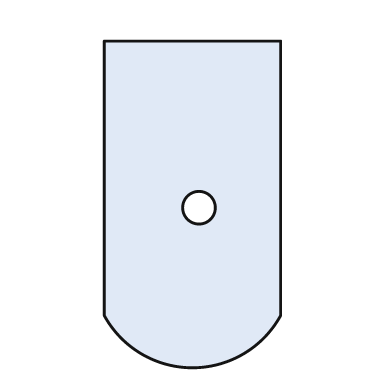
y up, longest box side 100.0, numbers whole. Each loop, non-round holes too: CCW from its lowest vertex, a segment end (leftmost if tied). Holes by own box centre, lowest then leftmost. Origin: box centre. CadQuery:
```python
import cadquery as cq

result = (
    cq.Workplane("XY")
    .moveTo(-27.0, -34.0)
    .threePointArc((0.0, -50.0), (27.0, -34.0))
    .lineTo(27.0, 50.0)
    .lineTo(-27.0, 50.0)
    .close()
    .moveTo(2.0, -1.0)
    .circle(5.0)
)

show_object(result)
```